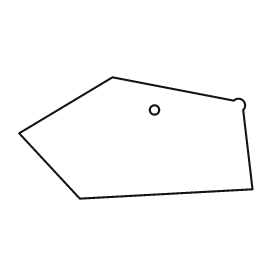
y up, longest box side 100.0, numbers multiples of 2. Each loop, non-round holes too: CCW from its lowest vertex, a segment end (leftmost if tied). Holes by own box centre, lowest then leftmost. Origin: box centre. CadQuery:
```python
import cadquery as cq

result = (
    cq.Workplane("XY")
    .moveTo(-24.0, -26.0)
    .lineTo(50.0, -22.0)
    .lineTo(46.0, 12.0)
    .threePointArc((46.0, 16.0), (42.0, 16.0))
    .lineTo(-10.0, 26.0)
    .lineTo(-50.0, 2.0)
    .close()
    .moveTo(8.0, 12.0)
    .circle(2.0)
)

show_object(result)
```